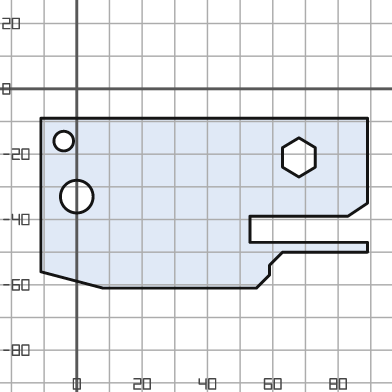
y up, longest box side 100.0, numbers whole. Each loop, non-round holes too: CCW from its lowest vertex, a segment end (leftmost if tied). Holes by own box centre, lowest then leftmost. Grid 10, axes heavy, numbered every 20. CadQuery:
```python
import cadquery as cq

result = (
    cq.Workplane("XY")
    .moveTo(8.0, -61.0)
    .lineTo(55.0, -61.0)
    .lineTo(59.0, -57.0)
    .lineTo(59.0, -54.0)
    .lineTo(63.0, -50.0)
    .lineTo(89.0, -50.0)
    .lineTo(89.0, -47.0)
    .lineTo(53.0, -47.0)
    .lineTo(53.0, -39.0)
    .lineTo(83.0, -39.0)
    .lineTo(89.0, -35.0)
    .lineTo(89.0, -9.0)
    .lineTo(-11.0, -9.0)
    .lineTo(-11.0, -56.0)
    .close()
    .moveTo(0.0, -33.0)
    .circle(5.0)
    .moveTo(68.0, -27.0)
    .lineTo(73.0, -24.0)
    .lineTo(73.0, -18.0)
    .lineTo(68.0, -15.0)
    .lineTo(63.0, -18.0)
    .lineTo(63.0, -24.0)
    .close()
    .moveTo(-4.0, -16.0)
    .circle(3.0)
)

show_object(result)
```